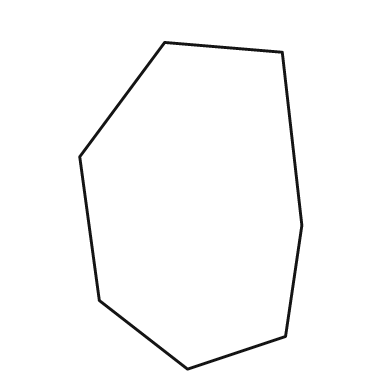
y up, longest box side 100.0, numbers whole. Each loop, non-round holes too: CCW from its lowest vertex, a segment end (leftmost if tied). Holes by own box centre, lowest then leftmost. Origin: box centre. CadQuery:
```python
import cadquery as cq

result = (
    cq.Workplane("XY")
    .moveTo(-1.0, -50.0)
    .lineTo(29.0, -40.0)
    .lineTo(34.0, -6.0)
    .lineTo(28.0, 47.0)
    .lineTo(-8.0, 50.0)
    .lineTo(-34.0, 15.0)
    .lineTo(-28.0, -29.0)
    .close()
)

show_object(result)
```